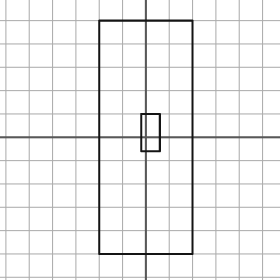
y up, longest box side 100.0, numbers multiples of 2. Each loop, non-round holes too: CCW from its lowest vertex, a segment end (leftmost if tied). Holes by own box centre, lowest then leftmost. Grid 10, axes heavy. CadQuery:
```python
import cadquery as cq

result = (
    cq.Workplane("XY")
    .moveTo(-20.0, -50.0)
    .lineTo(20.0, -50.0)
    .lineTo(20.0, 50.0)
    .lineTo(-20.0, 50.0)
    .close()
    .moveTo(-2.0, -6.0)
    .lineTo(6.0, -6.0)
    .lineTo(6.0, 10.0)
    .lineTo(-2.0, 10.0)
    .close()
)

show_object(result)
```